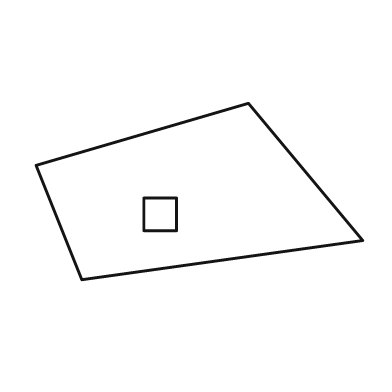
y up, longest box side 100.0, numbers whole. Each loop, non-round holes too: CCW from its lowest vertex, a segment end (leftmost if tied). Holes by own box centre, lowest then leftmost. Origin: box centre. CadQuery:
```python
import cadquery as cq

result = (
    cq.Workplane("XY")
    .moveTo(-36.0, -27.0)
    .lineTo(50.0, -15.0)
    .lineTo(15.0, 27.0)
    .lineTo(-50.0, 8.0)
    .close()
    .moveTo(-17.0, -12.0)
    .lineTo(-7.0, -12.0)
    .lineTo(-7.0, -2.0)
    .lineTo(-17.0, -2.0)
    .close()
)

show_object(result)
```